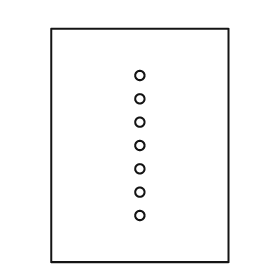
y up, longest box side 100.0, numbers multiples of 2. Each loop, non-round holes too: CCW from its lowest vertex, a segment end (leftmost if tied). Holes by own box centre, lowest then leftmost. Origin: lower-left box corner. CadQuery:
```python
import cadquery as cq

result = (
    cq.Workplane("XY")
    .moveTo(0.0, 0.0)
    .lineTo(76.0, 0.0)
    .lineTo(76.0, 100.0)
    .lineTo(0.0, 100.0)
    .close()
    .moveTo(38.0, 20.0)
    .circle(2.0)
    .moveTo(38.0, 30.0)
    .circle(2.0)
    .moveTo(38.0, 40.0)
    .circle(2.0)
    .moveTo(38.0, 50.0)
    .circle(2.0)
    .moveTo(38.0, 60.0)
    .circle(2.0)
    .moveTo(38.0, 70.0)
    .circle(2.0)
    .moveTo(38.0, 80.0)
    .circle(2.0)
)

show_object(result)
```